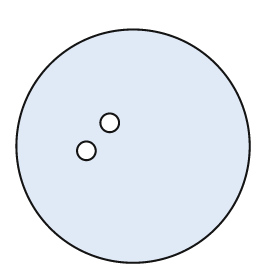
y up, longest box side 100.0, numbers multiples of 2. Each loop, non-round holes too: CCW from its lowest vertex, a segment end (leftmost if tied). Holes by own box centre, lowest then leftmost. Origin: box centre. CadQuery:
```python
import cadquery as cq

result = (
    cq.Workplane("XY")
    .moveTo(0.0, 0.0)
    .circle(50.0)
    .moveTo(-20.0, -2.0)
    .circle(4.0)
    .moveTo(-10.0, 10.0)
    .circle(4.0)
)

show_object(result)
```